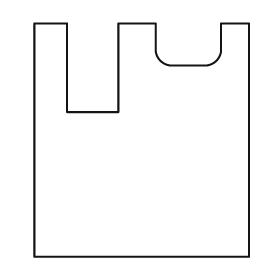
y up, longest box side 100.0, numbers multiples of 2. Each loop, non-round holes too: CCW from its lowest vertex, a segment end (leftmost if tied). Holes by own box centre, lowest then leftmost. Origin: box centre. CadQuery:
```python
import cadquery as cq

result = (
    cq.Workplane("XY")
    .moveTo(-46.0, -50.0)
    .lineTo(46.0, -50.0)
    .lineTo(46.0, 50.0)
    .lineTo(34.0, 50.0)
    .lineTo(34.0, 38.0)
    .threePointArc((32.0, 34.0), (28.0, 32.0))
    .lineTo(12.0, 32.0)
    .threePointArc((8.0, 34.0), (6.0, 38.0))
    .lineTo(6.0, 50.0)
    .lineTo(-10.0, 50.0)
    .lineTo(-10.0, 12.0)
    .lineTo(-32.0, 12.0)
    .lineTo(-32.0, 50.0)
    .lineTo(-46.0, 50.0)
    .close()
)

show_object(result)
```